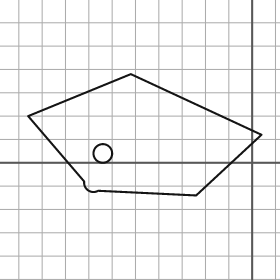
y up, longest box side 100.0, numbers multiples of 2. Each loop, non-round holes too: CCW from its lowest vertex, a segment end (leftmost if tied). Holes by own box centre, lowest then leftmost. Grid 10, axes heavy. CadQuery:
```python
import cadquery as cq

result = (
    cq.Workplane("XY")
    .moveTo(-24.0, -14.0)
    .lineTo(4.0, 12.0)
    .lineTo(-52.0, 38.0)
    .lineTo(-96.0, 20.0)
    .lineTo(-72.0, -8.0)
    .threePointArc((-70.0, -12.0), (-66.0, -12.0))
    .close()
    .moveTo(-64.0, 4.0)
    .circle(4.0)
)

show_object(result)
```